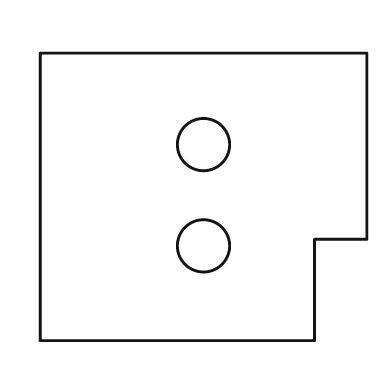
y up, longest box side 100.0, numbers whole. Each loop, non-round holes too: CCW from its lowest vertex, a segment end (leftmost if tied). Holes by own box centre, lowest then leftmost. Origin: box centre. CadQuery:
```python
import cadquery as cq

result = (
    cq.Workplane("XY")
    .moveTo(-50.0, -44.0)
    .lineTo(34.0, -44.0)
    .lineTo(34.0, -13.0)
    .lineTo(50.0, -13.0)
    .lineTo(50.0, 44.0)
    .lineTo(-50.0, 44.0)
    .close()
    .moveTo(0.0, -15.0)
    .circle(8.0)
    .moveTo(0.0, 16.0)
    .circle(8.0)
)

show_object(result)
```